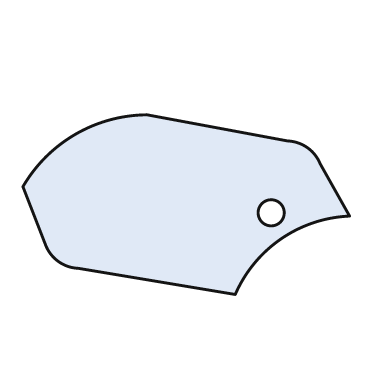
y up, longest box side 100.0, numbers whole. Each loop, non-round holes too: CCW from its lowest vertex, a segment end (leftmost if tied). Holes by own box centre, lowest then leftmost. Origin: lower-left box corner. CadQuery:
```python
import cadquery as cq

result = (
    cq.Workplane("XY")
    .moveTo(65.0, 0.0)
    .threePointArc((79.0, 17.0), (100.0, 24.0))
    .lineTo(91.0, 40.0)
    .threePointArc((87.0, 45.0), (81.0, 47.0))
    .lineTo(38.0, 55.0)
    .threePointArc((16.0, 49.0), (0.0, 33.0))
    .lineTo(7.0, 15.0)
    .threePointArc((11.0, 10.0), (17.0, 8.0))
    .close()
    .moveTo(76.0, 25.0)
    .circle(4.0)
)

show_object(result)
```